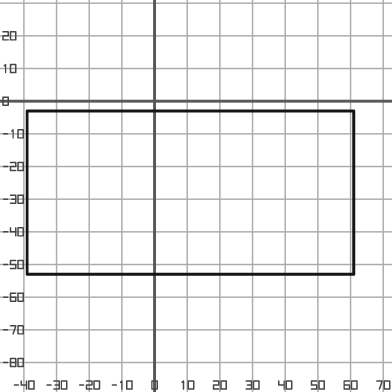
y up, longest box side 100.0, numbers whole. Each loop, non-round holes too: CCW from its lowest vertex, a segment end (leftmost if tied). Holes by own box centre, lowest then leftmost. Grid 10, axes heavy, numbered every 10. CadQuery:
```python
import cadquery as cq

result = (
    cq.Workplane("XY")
    .moveTo(-39.0, -53.0)
    .lineTo(61.0, -53.0)
    .lineTo(61.0, -3.0)
    .lineTo(-39.0, -3.0)
    .close()
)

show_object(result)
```